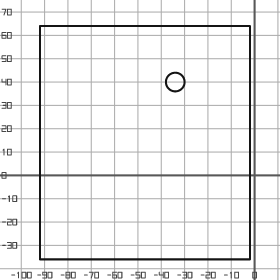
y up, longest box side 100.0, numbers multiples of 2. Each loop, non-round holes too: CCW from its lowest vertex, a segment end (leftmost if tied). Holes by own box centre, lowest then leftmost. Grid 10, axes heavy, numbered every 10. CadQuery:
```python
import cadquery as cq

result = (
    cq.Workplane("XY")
    .moveTo(-92.0, -36.0)
    .lineTo(-2.0, -36.0)
    .lineTo(-2.0, 64.0)
    .lineTo(-92.0, 64.0)
    .close()
    .moveTo(-34.0, 40.0)
    .circle(4.0)
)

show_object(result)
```